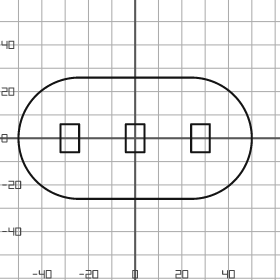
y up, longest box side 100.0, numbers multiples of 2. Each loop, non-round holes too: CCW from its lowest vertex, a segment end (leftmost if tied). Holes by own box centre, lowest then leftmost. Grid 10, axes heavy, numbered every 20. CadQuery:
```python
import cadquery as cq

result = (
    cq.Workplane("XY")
    .moveTo(-24.0, -26.0)
    .lineTo(24.0, -26.0)
    .threePointArc((50.0, 0.0), (24.0, 26.0))
    .lineTo(-24.0, 26.0)
    .threePointArc((-50.0, 0.0), (-24.0, -26.0))
    .close()
    .moveTo(-32.0, -6.0)
    .lineTo(-24.0, -6.0)
    .lineTo(-24.0, 6.0)
    .lineTo(-32.0, 6.0)
    .close()
    .moveTo(-4.0, -6.0)
    .lineTo(4.0, -6.0)
    .lineTo(4.0, 6.0)
    .lineTo(-4.0, 6.0)
    .close()
    .moveTo(24.0, -6.0)
    .lineTo(32.0, -6.0)
    .lineTo(32.0, 6.0)
    .lineTo(24.0, 6.0)
    .close()
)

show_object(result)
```